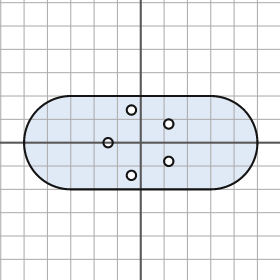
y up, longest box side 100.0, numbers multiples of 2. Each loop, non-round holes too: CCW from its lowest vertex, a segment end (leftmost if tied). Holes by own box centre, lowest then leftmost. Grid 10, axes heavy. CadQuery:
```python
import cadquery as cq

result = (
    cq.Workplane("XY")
    .moveTo(-30.0, -20.0)
    .lineTo(30.0, -20.0)
    .threePointArc((50.0, 0.0), (30.0, 20.0))
    .lineTo(-30.0, 20.0)
    .threePointArc((-50.0, 0.0), (-30.0, -20.0))
    .close()
    .moveTo(-4.0, -14.0)
    .circle(2.0)
    .moveTo(12.0, -8.0)
    .circle(2.0)
    .moveTo(-14.0, 0.0)
    .circle(2.0)
    .moveTo(12.0, 8.0)
    .circle(2.0)
    .moveTo(-4.0, 14.0)
    .circle(2.0)
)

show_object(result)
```